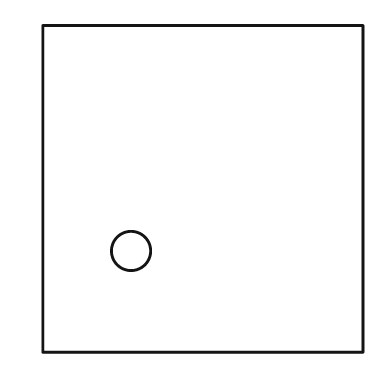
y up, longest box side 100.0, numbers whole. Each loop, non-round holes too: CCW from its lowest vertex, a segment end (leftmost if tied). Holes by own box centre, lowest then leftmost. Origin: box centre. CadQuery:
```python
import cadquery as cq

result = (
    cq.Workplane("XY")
    .moveTo(-49.0, -50.0)
    .lineTo(49.0, -50.0)
    .lineTo(49.0, 50.0)
    .lineTo(-49.0, 50.0)
    .close()
    .moveTo(-22.0, -19.0)
    .circle(6.0)
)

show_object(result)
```